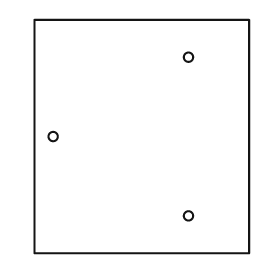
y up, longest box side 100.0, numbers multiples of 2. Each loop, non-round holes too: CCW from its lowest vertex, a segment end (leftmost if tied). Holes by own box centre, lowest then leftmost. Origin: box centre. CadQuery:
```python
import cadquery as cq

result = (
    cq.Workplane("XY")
    .moveTo(-46.0, -50.0)
    .lineTo(46.0, -50.0)
    .lineTo(46.0, 50.0)
    .lineTo(-46.0, 50.0)
    .close()
    .moveTo(20.0, -34.0)
    .circle(2.0)
    .moveTo(-38.0, 0.0)
    .circle(2.0)
    .moveTo(20.0, 34.0)
    .circle(2.0)
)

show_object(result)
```